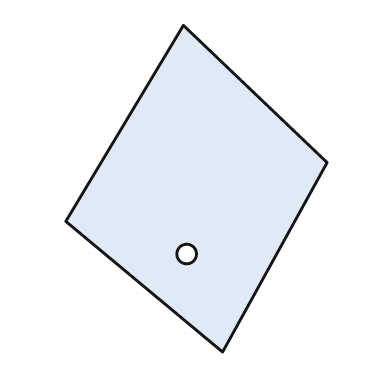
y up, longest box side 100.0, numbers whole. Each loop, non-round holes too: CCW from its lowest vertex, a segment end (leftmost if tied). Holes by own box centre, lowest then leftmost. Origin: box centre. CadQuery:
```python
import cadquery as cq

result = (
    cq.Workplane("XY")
    .moveTo(8.0, -50.0)
    .lineTo(40.0, 8.0)
    .lineTo(-4.0, 50.0)
    .lineTo(-40.0, -10.0)
    .close()
    .moveTo(-3.0, -20.0)
    .circle(3.0)
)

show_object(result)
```